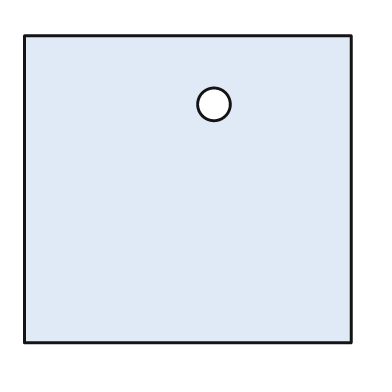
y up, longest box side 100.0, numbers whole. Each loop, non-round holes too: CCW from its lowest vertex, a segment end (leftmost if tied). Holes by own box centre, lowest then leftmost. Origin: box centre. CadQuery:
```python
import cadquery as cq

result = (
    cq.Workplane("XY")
    .moveTo(-50.0, -47.0)
    .lineTo(50.0, -47.0)
    .lineTo(50.0, 47.0)
    .lineTo(-50.0, 47.0)
    .close()
    .moveTo(8.0, 26.0)
    .circle(5.0)
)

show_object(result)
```